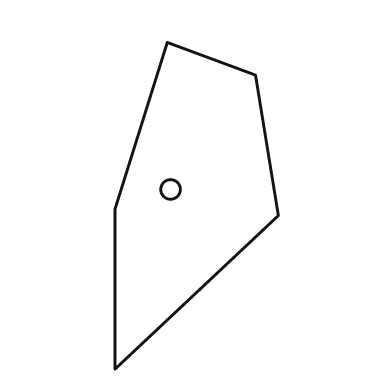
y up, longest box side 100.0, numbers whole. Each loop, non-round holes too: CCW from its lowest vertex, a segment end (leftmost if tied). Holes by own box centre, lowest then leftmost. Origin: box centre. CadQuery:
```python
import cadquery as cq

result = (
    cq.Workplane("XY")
    .moveTo(-25.0, -50.0)
    .lineTo(25.0, -3.0)
    .lineTo(18.0, 40.0)
    .lineTo(-9.0, 50.0)
    .lineTo(-25.0, -1.0)
    .close()
    .moveTo(-8.0, 5.0)
    .circle(3.0)
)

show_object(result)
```